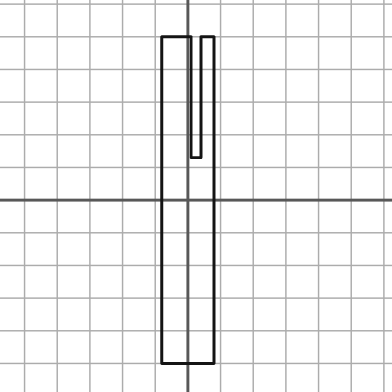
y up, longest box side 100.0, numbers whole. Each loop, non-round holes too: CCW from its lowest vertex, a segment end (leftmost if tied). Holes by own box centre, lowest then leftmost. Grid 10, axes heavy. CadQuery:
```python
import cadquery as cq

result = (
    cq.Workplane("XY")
    .moveTo(-8.0, -50.0)
    .lineTo(8.0, -50.0)
    .lineTo(8.0, 50.0)
    .lineTo(4.0, 50.0)
    .lineTo(4.0, 13.0)
    .lineTo(1.0, 13.0)
    .lineTo(1.0, 50.0)
    .lineTo(-8.0, 50.0)
    .close()
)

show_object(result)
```